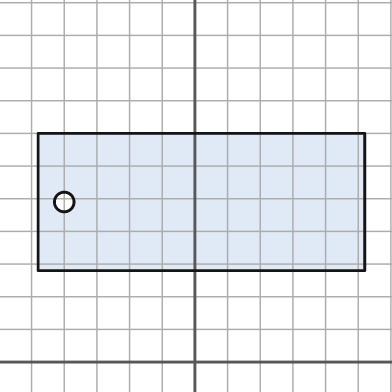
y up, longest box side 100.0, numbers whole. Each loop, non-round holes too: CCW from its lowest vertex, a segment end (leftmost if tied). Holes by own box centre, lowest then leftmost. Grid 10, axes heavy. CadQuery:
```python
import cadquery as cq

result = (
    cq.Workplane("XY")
    .moveTo(-48.0, 28.0)
    .lineTo(52.0, 28.0)
    .lineTo(52.0, 70.0)
    .lineTo(-48.0, 70.0)
    .close()
    .moveTo(-40.0, 49.0)
    .circle(3.0)
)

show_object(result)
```